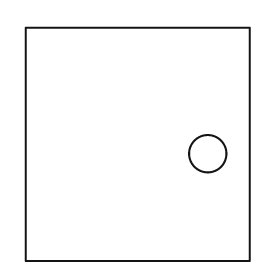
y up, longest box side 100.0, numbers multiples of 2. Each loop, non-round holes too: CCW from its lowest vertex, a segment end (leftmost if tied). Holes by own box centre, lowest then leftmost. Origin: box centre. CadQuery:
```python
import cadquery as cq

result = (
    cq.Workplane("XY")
    .moveTo(-48.0, -50.0)
    .lineTo(48.0, -50.0)
    .lineTo(48.0, 50.0)
    .lineTo(-48.0, 50.0)
    .close()
    .moveTo(30.0, -4.0)
    .circle(8.0)
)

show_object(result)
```